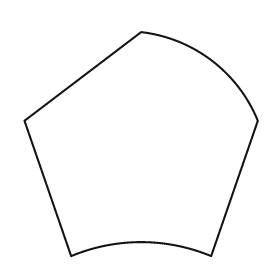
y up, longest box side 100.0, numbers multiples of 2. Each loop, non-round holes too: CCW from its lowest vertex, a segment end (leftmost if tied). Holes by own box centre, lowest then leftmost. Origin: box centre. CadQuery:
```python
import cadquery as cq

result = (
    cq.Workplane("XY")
    .moveTo(-30.0, -48.0)
    .threePointArc((0.0, -42.0), (30.0, -48.0))
    .lineTo(50.0, 10.0)
    .threePointArc((30.0, 36.0), (0.0, 48.0))
    .lineTo(-50.0, 10.0)
    .close()
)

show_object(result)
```